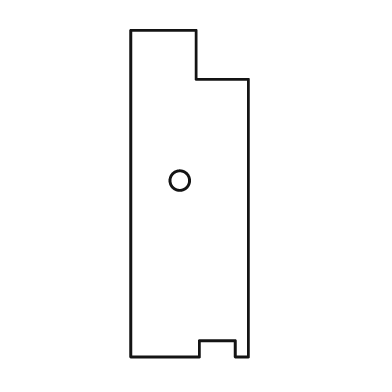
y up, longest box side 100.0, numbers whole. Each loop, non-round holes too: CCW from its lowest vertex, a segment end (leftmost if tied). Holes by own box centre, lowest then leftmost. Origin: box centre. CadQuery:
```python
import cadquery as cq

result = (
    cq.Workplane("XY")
    .moveTo(-18.0, -50.0)
    .lineTo(3.0, -50.0)
    .lineTo(3.0, -45.0)
    .lineTo(14.0, -45.0)
    .lineTo(14.0, -50.0)
    .lineTo(18.0, -50.0)
    .lineTo(18.0, 35.0)
    .lineTo(2.0, 35.0)
    .lineTo(2.0, 50.0)
    .lineTo(-18.0, 50.0)
    .close()
    .moveTo(-3.0, 4.0)
    .circle(3.0)
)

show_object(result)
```